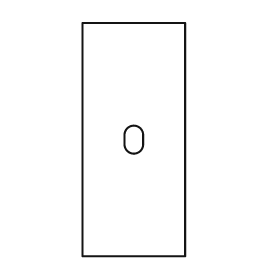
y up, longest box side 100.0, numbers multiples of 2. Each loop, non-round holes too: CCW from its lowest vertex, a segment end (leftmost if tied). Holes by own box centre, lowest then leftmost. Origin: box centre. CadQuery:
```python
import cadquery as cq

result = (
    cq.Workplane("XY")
    .moveTo(-22.0, -50.0)
    .lineTo(22.0, -50.0)
    .lineTo(22.0, 50.0)
    .lineTo(-22.0, 50.0)
    .close()
    .moveTo(-4.0, -2.0)
    .threePointArc((0.0, -6.0), (4.0, -2.0))
    .lineTo(4.0, 2.0)
    .threePointArc((0.0, 6.0), (-4.0, 2.0))
    .close()
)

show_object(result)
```